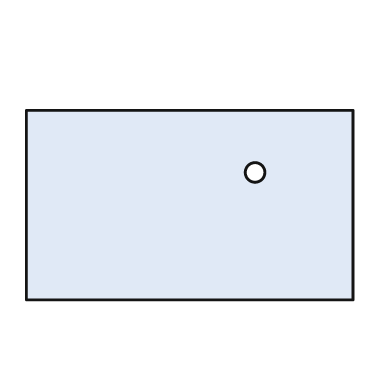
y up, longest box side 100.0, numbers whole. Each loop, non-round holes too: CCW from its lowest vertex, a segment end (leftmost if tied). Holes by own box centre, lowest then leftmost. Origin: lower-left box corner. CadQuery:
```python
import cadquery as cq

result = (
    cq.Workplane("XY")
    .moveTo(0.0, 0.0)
    .lineTo(100.0, 0.0)
    .lineTo(100.0, 58.0)
    .lineTo(0.0, 58.0)
    .close()
    .moveTo(70.0, 39.0)
    .circle(3.0)
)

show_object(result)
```